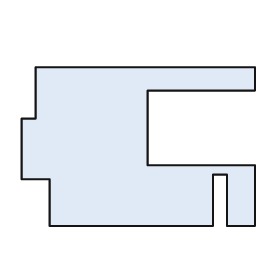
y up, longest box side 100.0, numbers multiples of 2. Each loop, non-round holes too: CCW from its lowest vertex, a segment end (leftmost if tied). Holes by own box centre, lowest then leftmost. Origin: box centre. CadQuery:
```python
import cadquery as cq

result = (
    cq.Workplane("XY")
    .moveTo(-38.0, -34.0)
    .lineTo(32.0, -34.0)
    .lineTo(32.0, -12.0)
    .lineTo(38.0, -12.0)
    .lineTo(38.0, -34.0)
    .lineTo(50.0, -34.0)
    .lineTo(50.0, -8.0)
    .lineTo(4.0, -8.0)
    .lineTo(4.0, 24.0)
    .lineTo(50.0, 24.0)
    .lineTo(50.0, 34.0)
    .lineTo(-44.0, 34.0)
    .lineTo(-44.0, 12.0)
    .lineTo(-50.0, 12.0)
    .lineTo(-50.0, -14.0)
    .lineTo(-38.0, -14.0)
    .close()
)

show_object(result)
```